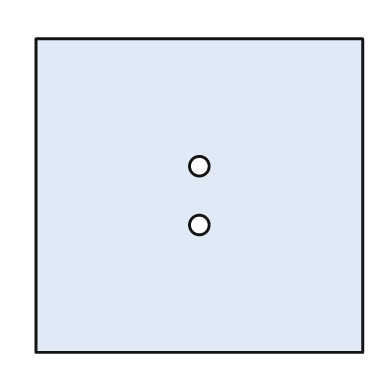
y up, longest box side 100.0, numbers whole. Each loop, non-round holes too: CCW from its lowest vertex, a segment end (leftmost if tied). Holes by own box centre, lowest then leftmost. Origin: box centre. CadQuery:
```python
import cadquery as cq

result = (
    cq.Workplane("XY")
    .moveTo(-50.0, -48.0)
    .lineTo(50.0, -48.0)
    .lineTo(50.0, 48.0)
    .lineTo(-50.0, 48.0)
    .close()
    .moveTo(0.0, -9.0)
    .circle(3.0)
    .moveTo(0.0, 9.0)
    .circle(3.0)
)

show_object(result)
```